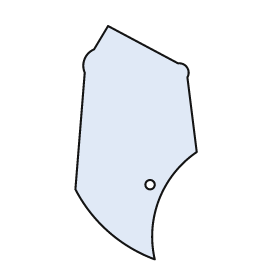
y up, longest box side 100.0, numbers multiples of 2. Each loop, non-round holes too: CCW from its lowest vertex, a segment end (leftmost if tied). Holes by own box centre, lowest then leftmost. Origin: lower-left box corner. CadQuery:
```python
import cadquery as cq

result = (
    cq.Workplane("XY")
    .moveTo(34.0, 0.0)
    .threePointArc((36.0, 26.0), (52.0, 46.0))
    .lineTo(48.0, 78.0)
    .threePointArc((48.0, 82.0), (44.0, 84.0))
    .lineTo(14.0, 100.0)
    .lineTo(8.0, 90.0)
    .threePointArc((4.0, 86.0), (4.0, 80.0))
    .lineTo(0.0, 30.0)
    .threePointArc((14.0, 12.0), (34.0, 0.0))
    .close()
    .moveTo(32.0, 32.0)
    .circle(2.0)
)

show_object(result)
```